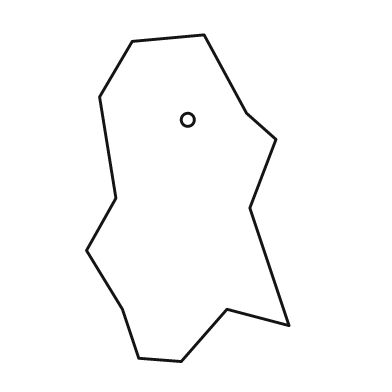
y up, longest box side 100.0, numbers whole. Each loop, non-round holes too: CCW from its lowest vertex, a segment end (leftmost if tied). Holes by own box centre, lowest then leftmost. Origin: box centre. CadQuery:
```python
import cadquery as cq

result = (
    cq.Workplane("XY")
    .moveTo(-2.0, -50.0)
    .lineTo(12.0, -34.0)
    .lineTo(31.0, -39.0)
    .lineTo(19.0, -3.0)
    .lineTo(27.0, 18.0)
    .lineTo(18.0, 26.0)
    .lineTo(5.0, 50.0)
    .lineTo(-17.0, 48.0)
    .lineTo(-27.0, 31.0)
    .lineTo(-22.0, 0.0)
    .lineTo(-31.0, -16.0)
    .lineTo(-20.0, -34.0)
    .lineTo(-15.0, -49.0)
    .close()
    .moveTo(0.0, 24.0)
    .circle(2.0)
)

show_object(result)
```